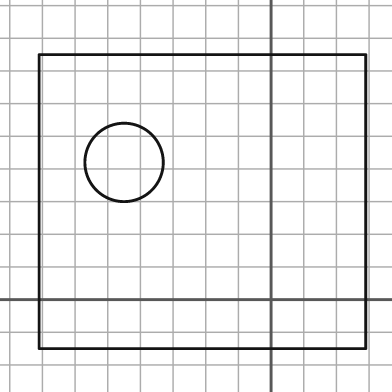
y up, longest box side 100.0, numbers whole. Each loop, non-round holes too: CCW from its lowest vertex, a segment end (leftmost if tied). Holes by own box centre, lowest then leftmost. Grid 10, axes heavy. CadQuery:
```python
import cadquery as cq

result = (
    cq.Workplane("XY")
    .moveTo(-71.0, -15.0)
    .lineTo(29.0, -15.0)
    .lineTo(29.0, 75.0)
    .lineTo(-71.0, 75.0)
    .close()
    .moveTo(-45.0, 42.0)
    .circle(12.0)
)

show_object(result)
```